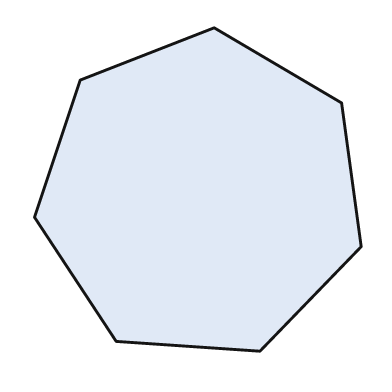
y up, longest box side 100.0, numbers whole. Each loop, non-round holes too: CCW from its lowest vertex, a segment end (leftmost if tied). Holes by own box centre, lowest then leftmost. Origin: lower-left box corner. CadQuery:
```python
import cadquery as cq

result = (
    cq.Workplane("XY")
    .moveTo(69.0, 0.0)
    .lineTo(100.0, 32.0)
    .lineTo(94.0, 76.0)
    .lineTo(55.0, 99.0)
    .lineTo(14.0, 83.0)
    .lineTo(0.0, 41.0)
    .lineTo(25.0, 3.0)
    .close()
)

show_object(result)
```